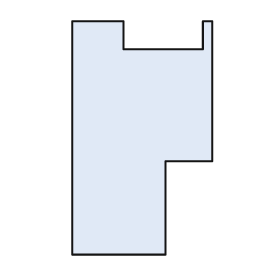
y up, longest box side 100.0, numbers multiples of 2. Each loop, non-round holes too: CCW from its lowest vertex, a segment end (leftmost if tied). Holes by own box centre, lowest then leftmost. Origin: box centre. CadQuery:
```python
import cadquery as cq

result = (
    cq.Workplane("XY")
    .moveTo(-30.0, -50.0)
    .lineTo(10.0, -50.0)
    .lineTo(10.0, -10.0)
    .lineTo(30.0, -10.0)
    .lineTo(30.0, 50.0)
    .lineTo(26.0, 50.0)
    .lineTo(26.0, 38.0)
    .lineTo(-8.0, 38.0)
    .lineTo(-8.0, 50.0)
    .lineTo(-30.0, 50.0)
    .close()
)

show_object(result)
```